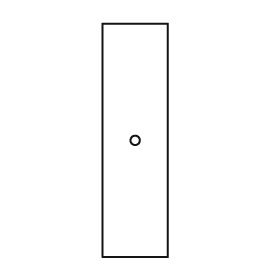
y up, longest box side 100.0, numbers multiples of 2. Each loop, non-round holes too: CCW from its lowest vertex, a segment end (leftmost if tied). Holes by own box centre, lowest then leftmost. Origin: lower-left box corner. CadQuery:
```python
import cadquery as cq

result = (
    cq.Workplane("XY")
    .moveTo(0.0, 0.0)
    .lineTo(28.0, 0.0)
    .lineTo(28.0, 100.0)
    .lineTo(0.0, 100.0)
    .close()
    .moveTo(14.0, 50.0)
    .circle(2.0)
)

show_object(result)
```